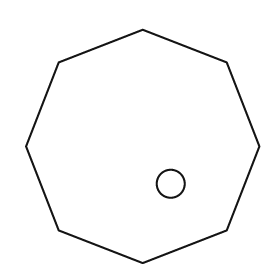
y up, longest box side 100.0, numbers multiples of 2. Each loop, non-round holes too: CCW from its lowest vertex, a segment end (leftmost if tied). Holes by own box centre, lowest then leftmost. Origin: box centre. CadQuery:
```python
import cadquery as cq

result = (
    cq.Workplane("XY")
    .moveTo(0.0, -50.0)
    .lineTo(36.0, -36.0)
    .lineTo(50.0, 0.0)
    .lineTo(36.0, 36.0)
    .lineTo(0.0, 50.0)
    .lineTo(-36.0, 36.0)
    .lineTo(-50.0, 0.0)
    .lineTo(-36.0, -36.0)
    .close()
    .moveTo(12.0, -16.0)
    .circle(6.0)
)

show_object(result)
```